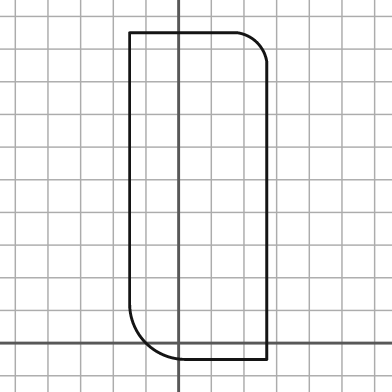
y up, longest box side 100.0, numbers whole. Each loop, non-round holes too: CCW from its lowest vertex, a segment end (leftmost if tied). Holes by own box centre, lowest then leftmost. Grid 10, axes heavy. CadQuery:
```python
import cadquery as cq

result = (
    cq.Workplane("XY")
    .moveTo(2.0, -5.0)
    .lineTo(27.0, -5.0)
    .lineTo(27.0, 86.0)
    .threePointArc((24.0, 92.0), (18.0, 95.0))
    .lineTo(-15.0, 95.0)
    .lineTo(-15.0, 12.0)
    .threePointArc((-10.0, 0.0), (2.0, -5.0))
    .close()
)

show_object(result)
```